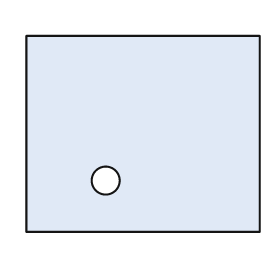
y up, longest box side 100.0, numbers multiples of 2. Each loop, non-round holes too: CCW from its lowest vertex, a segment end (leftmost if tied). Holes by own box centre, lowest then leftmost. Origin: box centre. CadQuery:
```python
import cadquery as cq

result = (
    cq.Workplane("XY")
    .moveTo(-50.0, -42.0)
    .lineTo(50.0, -42.0)
    .lineTo(50.0, 42.0)
    .lineTo(-50.0, 42.0)
    .close()
    .moveTo(-16.0, -20.0)
    .circle(6.0)
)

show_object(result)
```